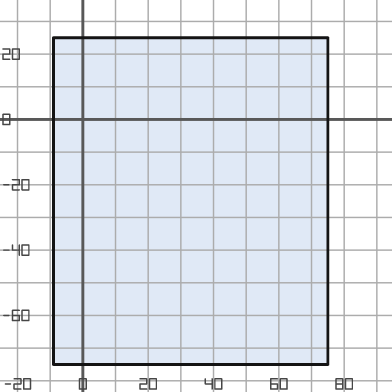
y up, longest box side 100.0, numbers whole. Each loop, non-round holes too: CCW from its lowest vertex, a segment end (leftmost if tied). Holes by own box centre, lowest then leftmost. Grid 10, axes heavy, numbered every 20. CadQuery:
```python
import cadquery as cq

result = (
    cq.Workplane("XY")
    .moveTo(-9.0, -75.0)
    .lineTo(75.0, -75.0)
    .lineTo(75.0, 25.0)
    .lineTo(-9.0, 25.0)
    .close()
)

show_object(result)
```